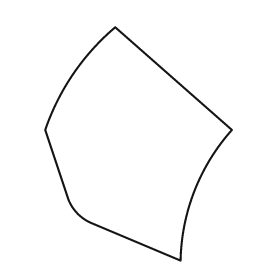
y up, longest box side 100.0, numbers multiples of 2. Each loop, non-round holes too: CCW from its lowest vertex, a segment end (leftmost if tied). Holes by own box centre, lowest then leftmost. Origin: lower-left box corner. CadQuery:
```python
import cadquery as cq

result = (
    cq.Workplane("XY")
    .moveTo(58.0, 0.0)
    .threePointArc((64.0, 30.0), (80.0, 56.0))
    .lineTo(30.0, 100.0)
    .threePointArc((12.0, 80.0), (0.0, 56.0))
    .lineTo(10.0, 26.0)
    .threePointArc((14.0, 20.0), (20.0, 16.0))
    .close()
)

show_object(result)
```